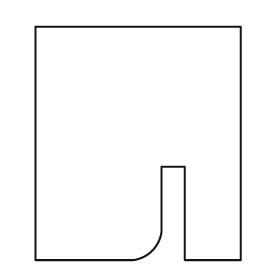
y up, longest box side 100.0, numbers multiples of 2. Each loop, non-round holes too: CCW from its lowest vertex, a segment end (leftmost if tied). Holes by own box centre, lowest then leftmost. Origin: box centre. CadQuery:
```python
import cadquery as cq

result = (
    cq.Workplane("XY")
    .moveTo(-44.0, -50.0)
    .lineTo(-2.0, -50.0)
    .threePointArc((6.0, -46.0), (10.0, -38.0))
    .lineTo(10.0, -10.0)
    .lineTo(20.0, -10.0)
    .lineTo(20.0, -50.0)
    .lineTo(44.0, -50.0)
    .lineTo(44.0, 50.0)
    .lineTo(-44.0, 50.0)
    .close()
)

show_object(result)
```